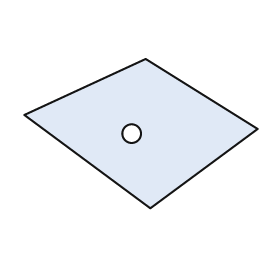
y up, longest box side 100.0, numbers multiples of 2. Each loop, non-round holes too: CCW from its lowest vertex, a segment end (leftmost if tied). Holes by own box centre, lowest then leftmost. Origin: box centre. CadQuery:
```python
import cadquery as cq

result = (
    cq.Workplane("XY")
    .moveTo(4.0, -32.0)
    .lineTo(50.0, 2.0)
    .lineTo(2.0, 32.0)
    .lineTo(-50.0, 8.0)
    .close()
    .moveTo(-4.0, 0.0)
    .circle(4.0)
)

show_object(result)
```